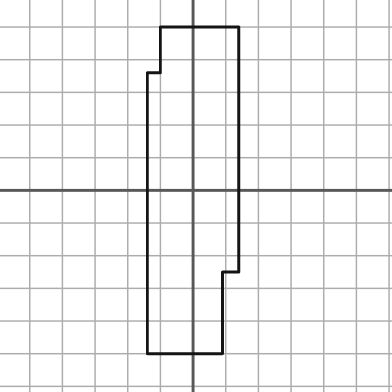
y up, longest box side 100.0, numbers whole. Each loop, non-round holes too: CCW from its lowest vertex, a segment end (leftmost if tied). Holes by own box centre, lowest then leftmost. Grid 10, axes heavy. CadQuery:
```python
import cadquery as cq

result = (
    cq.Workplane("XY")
    .moveTo(-14.0, -50.0)
    .lineTo(9.0, -50.0)
    .lineTo(9.0, -25.0)
    .lineTo(14.0, -25.0)
    .lineTo(14.0, 50.0)
    .lineTo(-10.0, 50.0)
    .lineTo(-10.0, 36.0)
    .lineTo(-14.0, 36.0)
    .close()
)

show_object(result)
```